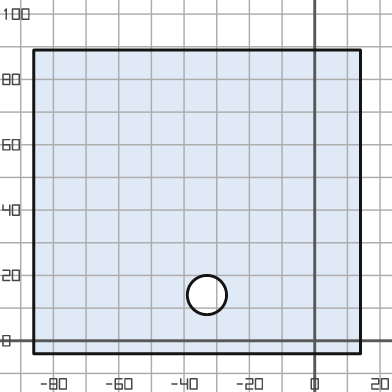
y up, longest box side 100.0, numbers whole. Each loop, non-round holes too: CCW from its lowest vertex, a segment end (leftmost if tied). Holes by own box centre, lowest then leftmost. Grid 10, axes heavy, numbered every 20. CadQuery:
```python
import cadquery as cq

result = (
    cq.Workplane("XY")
    .moveTo(-86.0, -4.0)
    .lineTo(14.0, -4.0)
    .lineTo(14.0, 89.0)
    .lineTo(-86.0, 89.0)
    .close()
    .moveTo(-33.0, 14.0)
    .circle(6.0)
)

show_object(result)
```